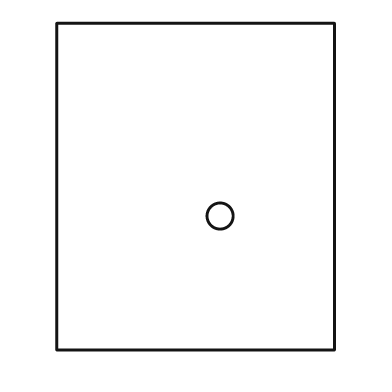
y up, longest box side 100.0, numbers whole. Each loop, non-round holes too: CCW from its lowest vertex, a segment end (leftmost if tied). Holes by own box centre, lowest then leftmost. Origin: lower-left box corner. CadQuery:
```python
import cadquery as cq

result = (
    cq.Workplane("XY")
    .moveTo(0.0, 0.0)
    .lineTo(85.0, 0.0)
    .lineTo(85.0, 100.0)
    .lineTo(0.0, 100.0)
    .close()
    .moveTo(50.0, 41.0)
    .circle(4.0)
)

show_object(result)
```